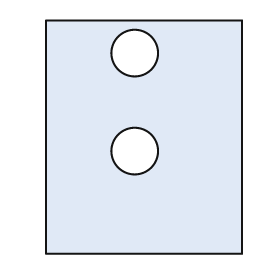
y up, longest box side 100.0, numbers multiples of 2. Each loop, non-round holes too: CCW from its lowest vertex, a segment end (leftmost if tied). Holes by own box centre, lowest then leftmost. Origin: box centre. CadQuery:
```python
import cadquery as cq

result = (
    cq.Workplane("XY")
    .moveTo(-42.0, -50.0)
    .lineTo(42.0, -50.0)
    .lineTo(42.0, 50.0)
    .lineTo(-42.0, 50.0)
    .close()
    .moveTo(-4.0, -6.0)
    .circle(10.0)
    .moveTo(-4.0, 36.0)
    .circle(10.0)
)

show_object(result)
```